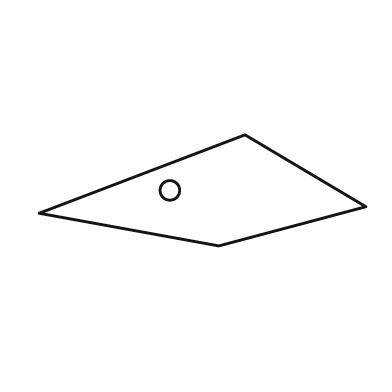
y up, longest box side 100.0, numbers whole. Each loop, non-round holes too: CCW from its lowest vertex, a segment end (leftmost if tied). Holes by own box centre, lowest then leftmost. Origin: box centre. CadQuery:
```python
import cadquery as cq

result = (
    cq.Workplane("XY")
    .moveTo(5.0, -17.0)
    .lineTo(50.0, -5.0)
    .lineTo(13.0, 17.0)
    .lineTo(-50.0, -7.0)
    .close()
    .moveTo(-10.0, 0.0)
    .circle(3.0)
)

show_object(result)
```